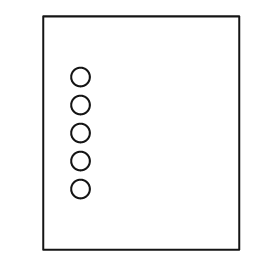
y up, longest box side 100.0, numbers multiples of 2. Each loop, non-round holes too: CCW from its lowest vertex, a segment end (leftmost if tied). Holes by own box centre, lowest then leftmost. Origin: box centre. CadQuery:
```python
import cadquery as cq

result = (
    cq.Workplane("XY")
    .moveTo(-42.0, -50.0)
    .lineTo(42.0, -50.0)
    .lineTo(42.0, 50.0)
    .lineTo(-42.0, 50.0)
    .close()
    .moveTo(-26.0, -24.0)
    .circle(4.0)
    .moveTo(-26.0, -12.0)
    .circle(4.0)
    .moveTo(-26.0, 0.0)
    .circle(4.0)
    .moveTo(-26.0, 12.0)
    .circle(4.0)
    .moveTo(-26.0, 24.0)
    .circle(4.0)
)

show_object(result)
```